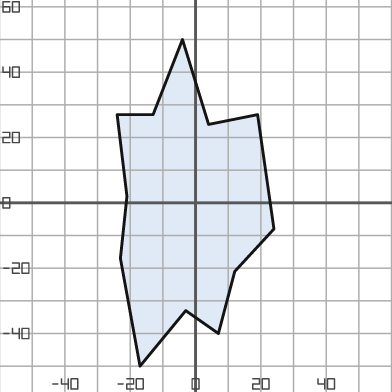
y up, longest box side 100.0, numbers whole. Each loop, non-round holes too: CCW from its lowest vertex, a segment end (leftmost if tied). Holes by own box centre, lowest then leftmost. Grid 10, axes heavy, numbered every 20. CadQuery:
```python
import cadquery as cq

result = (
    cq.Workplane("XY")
    .moveTo(-17.0, -50.0)
    .lineTo(-3.0, -33.0)
    .lineTo(7.0, -40.0)
    .lineTo(12.0, -21.0)
    .lineTo(24.0, -8.0)
    .lineTo(19.0, 27.0)
    .lineTo(4.0, 24.0)
    .lineTo(-4.0, 50.0)
    .lineTo(-13.0, 27.0)
    .lineTo(-24.0, 27.0)
    .lineTo(-21.0, 2.0)
    .lineTo(-23.0, -17.0)
    .close()
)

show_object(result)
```